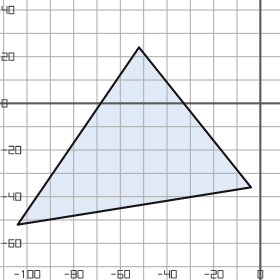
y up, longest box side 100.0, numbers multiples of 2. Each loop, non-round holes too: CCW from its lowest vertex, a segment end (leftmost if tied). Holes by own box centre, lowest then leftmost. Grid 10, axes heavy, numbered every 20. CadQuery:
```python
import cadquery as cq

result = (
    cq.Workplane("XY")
    .moveTo(-104.0, -52.0)
    .lineTo(-4.0, -36.0)
    .lineTo(-52.0, 24.0)
    .close()
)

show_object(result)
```